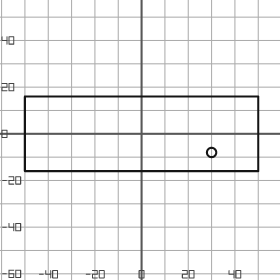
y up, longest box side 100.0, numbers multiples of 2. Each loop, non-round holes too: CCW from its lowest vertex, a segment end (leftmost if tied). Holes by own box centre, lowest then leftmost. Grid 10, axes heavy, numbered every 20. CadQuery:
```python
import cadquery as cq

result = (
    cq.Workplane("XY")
    .moveTo(-50.0, -16.0)
    .lineTo(50.0, -16.0)
    .lineTo(50.0, 16.0)
    .lineTo(-50.0, 16.0)
    .close()
    .moveTo(30.0, -8.0)
    .circle(2.0)
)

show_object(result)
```